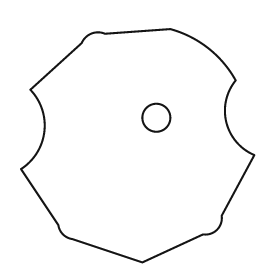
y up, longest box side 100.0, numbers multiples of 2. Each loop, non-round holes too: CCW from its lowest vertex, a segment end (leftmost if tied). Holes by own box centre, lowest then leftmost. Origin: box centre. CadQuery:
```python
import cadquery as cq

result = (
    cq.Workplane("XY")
    .moveTo(2.0, -50.0)
    .lineTo(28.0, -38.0)
    .threePointArc((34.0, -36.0), (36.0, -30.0))
    .lineTo(50.0, -4.0)
    .threePointArc((38.0, 10.0), (42.0, 28.0))
    .threePointArc((30.0, 42.0), (14.0, 50.0))
    .lineTo(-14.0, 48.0)
    .threePointArc((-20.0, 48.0), (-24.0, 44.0))
    .lineTo(-46.0, 24.0)
    .threePointArc((-40.0, 6.0), (-50.0, -10.0))
    .lineTo(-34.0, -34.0)
    .threePointArc((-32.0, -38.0), (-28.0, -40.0))
    .close()
    .moveTo(8.0, 12.0)
    .circle(6.0)
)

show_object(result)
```